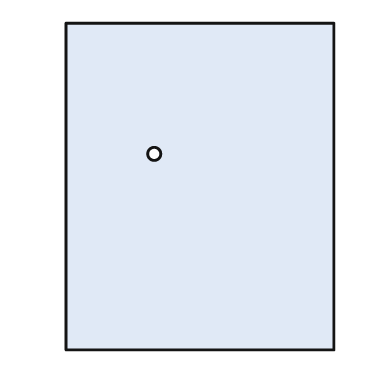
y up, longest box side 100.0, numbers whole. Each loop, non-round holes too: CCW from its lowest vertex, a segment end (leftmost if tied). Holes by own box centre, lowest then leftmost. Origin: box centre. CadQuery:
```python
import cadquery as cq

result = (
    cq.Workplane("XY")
    .moveTo(-41.0, -50.0)
    .lineTo(41.0, -50.0)
    .lineTo(41.0, 50.0)
    .lineTo(-41.0, 50.0)
    .close()
    .moveTo(-14.0, 10.0)
    .circle(2.0)
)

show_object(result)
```